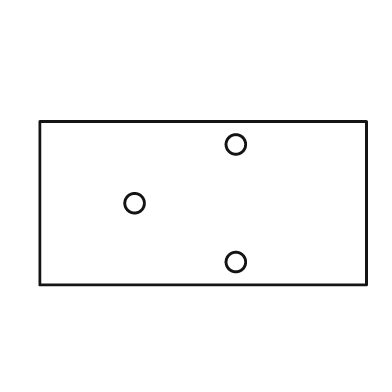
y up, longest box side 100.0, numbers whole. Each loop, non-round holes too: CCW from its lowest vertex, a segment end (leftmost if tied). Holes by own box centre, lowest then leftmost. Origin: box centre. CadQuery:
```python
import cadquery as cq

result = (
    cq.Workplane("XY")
    .moveTo(-50.0, -25.0)
    .lineTo(50.0, -25.0)
    .lineTo(50.0, 25.0)
    .lineTo(-50.0, 25.0)
    .close()
    .moveTo(10.0, -18.0)
    .circle(3.0)
    .moveTo(-21.0, 0.0)
    .circle(3.0)
    .moveTo(10.0, 18.0)
    .circle(3.0)
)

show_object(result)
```